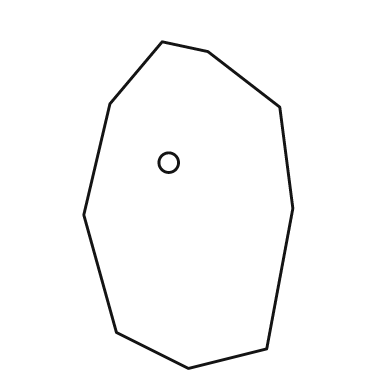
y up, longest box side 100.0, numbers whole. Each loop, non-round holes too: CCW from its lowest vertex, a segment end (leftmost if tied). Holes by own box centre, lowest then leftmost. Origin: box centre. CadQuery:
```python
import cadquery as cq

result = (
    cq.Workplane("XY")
    .moveTo(0.0, -50.0)
    .lineTo(24.0, -44.0)
    .lineTo(32.0, -1.0)
    .lineTo(28.0, 30.0)
    .lineTo(6.0, 47.0)
    .lineTo(-8.0, 50.0)
    .lineTo(-24.0, 31.0)
    .lineTo(-32.0, -3.0)
    .lineTo(-22.0, -39.0)
    .close()
    .moveTo(-6.0, 13.0)
    .circle(3.0)
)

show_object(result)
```